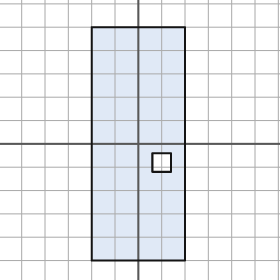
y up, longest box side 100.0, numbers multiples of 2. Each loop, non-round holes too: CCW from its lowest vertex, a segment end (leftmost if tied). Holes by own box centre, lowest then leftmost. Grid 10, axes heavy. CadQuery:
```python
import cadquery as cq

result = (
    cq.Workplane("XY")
    .moveTo(-20.0, -50.0)
    .lineTo(20.0, -50.0)
    .lineTo(20.0, 50.0)
    .lineTo(-20.0, 50.0)
    .close()
    .moveTo(6.0, -12.0)
    .lineTo(14.0, -12.0)
    .lineTo(14.0, -4.0)
    .lineTo(6.0, -4.0)
    .close()
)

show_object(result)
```